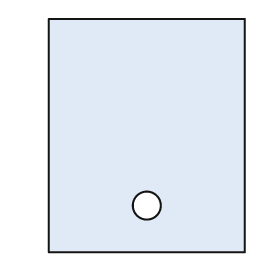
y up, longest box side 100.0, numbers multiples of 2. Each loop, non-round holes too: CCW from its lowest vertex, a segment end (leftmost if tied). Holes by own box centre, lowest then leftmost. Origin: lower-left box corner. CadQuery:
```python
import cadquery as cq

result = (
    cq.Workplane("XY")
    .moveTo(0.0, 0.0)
    .lineTo(84.0, 0.0)
    .lineTo(84.0, 100.0)
    .lineTo(0.0, 100.0)
    .close()
    .moveTo(42.0, 20.0)
    .circle(6.0)
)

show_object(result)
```